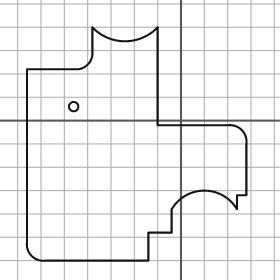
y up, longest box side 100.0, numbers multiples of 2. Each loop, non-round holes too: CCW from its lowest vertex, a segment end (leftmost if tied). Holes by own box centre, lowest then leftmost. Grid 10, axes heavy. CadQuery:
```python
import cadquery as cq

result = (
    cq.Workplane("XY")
    .moveTo(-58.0, -60.0)
    .lineTo(-14.0, -60.0)
    .lineTo(-14.0, -48.0)
    .lineTo(-4.0, -48.0)
    .lineTo(-4.0, -38.0)
    .threePointArc((10.0, -30.0), (24.0, -38.0))
    .lineTo(24.0, -32.0)
    .lineTo(28.0, -32.0)
    .lineTo(28.0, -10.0)
    .threePointArc((26.0, -4.0), (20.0, -2.0))
    .lineTo(-10.0, -2.0)
    .lineTo(-10.0, 40.0)
    .threePointArc((-24.0, 34.0), (-38.0, 40.0))
    .lineTo(-38.0, 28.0)
    .threePointArc((-40.0, 24.0), (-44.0, 22.0))
    .lineTo(-66.0, 22.0)
    .lineTo(-66.0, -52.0)
    .threePointArc((-64.0, -58.0), (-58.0, -60.0))
    .close()
    .moveTo(-46.0, 6.0)
    .circle(2.0)
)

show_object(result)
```